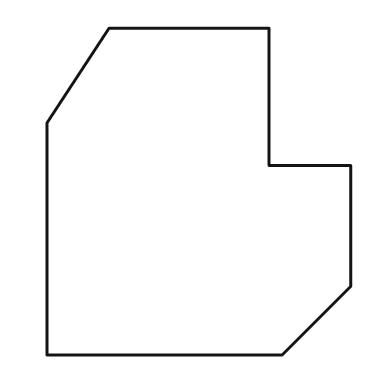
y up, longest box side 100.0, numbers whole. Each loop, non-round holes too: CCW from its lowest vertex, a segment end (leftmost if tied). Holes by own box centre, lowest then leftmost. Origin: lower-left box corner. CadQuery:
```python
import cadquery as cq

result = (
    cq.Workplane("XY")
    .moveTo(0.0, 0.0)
    .lineTo(72.0, 0.0)
    .lineTo(93.0, 21.0)
    .lineTo(93.0, 58.0)
    .lineTo(68.0, 58.0)
    .lineTo(68.0, 100.0)
    .lineTo(19.0, 100.0)
    .lineTo(0.0, 71.0)
    .close()
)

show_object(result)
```